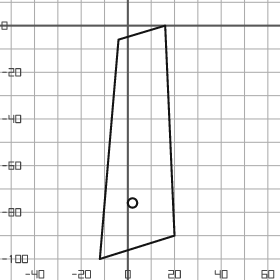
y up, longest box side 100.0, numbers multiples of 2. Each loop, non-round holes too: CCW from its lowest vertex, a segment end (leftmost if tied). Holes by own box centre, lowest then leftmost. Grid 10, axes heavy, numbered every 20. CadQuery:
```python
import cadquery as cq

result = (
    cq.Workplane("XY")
    .moveTo(-12.0, -100.0)
    .lineTo(20.0, -90.0)
    .lineTo(16.0, 0.0)
    .lineTo(-4.0, -6.0)
    .close()
    .moveTo(2.0, -76.0)
    .circle(2.0)
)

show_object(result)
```